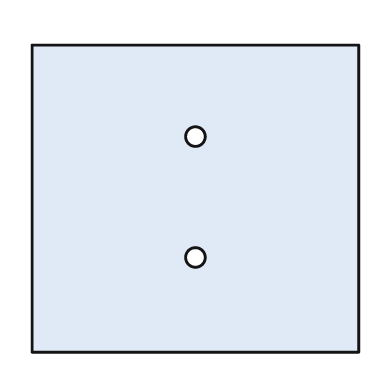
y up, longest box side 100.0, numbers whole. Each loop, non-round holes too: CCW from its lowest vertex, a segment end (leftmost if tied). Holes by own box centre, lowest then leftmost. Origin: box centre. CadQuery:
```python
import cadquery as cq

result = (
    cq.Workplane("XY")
    .moveTo(-50.0, -47.0)
    .lineTo(50.0, -47.0)
    .lineTo(50.0, 47.0)
    .lineTo(-50.0, 47.0)
    .close()
    .moveTo(0.0, -18.0)
    .circle(3.0)
    .moveTo(0.0, 19.0)
    .circle(3.0)
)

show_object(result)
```